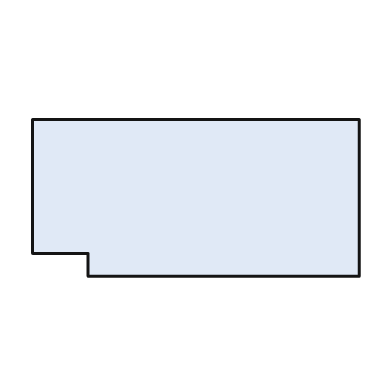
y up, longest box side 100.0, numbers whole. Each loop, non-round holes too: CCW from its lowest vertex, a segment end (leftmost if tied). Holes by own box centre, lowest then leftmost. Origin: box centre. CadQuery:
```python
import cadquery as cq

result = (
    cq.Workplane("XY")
    .moveTo(-33.0, -24.0)
    .lineTo(50.0, -24.0)
    .lineTo(50.0, 24.0)
    .lineTo(-50.0, 24.0)
    .lineTo(-50.0, -17.0)
    .lineTo(-33.0, -17.0)
    .close()
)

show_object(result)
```